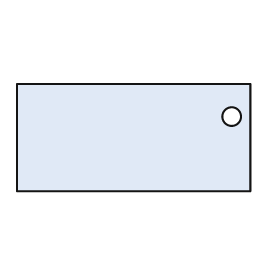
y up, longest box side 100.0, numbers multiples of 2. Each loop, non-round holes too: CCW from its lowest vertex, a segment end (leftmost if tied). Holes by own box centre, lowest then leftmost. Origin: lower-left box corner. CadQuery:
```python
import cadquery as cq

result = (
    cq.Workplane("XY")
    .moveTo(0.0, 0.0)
    .lineTo(100.0, 0.0)
    .lineTo(100.0, 46.0)
    .lineTo(0.0, 46.0)
    .close()
    .moveTo(92.0, 32.0)
    .circle(4.0)
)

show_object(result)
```